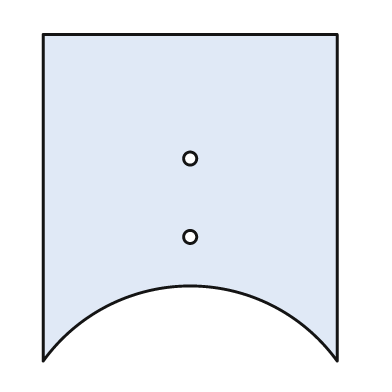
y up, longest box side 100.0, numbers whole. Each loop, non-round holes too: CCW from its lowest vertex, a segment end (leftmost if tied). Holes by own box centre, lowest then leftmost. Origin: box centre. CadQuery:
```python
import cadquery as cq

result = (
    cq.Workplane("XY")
    .moveTo(-45.0, -50.0)
    .threePointArc((0.0, -27.0), (45.0, -50.0))
    .lineTo(45.0, 50.0)
    .lineTo(-45.0, 50.0)
    .close()
    .moveTo(0.0, -12.0)
    .circle(2.0)
    .moveTo(0.0, 12.0)
    .circle(2.0)
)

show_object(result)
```